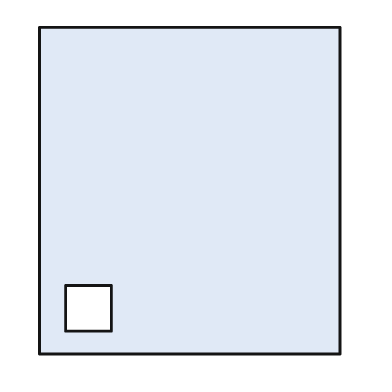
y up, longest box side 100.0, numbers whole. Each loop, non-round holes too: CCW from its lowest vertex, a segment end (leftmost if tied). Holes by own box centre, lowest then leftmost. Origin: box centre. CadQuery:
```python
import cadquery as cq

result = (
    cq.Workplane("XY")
    .moveTo(-46.0, -50.0)
    .lineTo(46.0, -50.0)
    .lineTo(46.0, 50.0)
    .lineTo(-46.0, 50.0)
    .close()
    .moveTo(-38.0, -43.0)
    .lineTo(-24.0, -43.0)
    .lineTo(-24.0, -29.0)
    .lineTo(-38.0, -29.0)
    .close()
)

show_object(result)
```